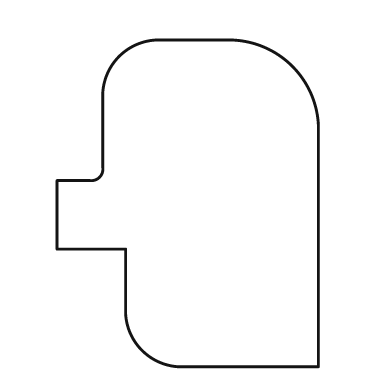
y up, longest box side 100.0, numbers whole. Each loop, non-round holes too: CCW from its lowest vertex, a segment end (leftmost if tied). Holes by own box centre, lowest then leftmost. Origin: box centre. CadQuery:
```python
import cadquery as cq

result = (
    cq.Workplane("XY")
    .moveTo(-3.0, -50.0)
    .lineTo(40.0, -50.0)
    .lineTo(40.0, 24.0)
    .threePointArc((32.0, 42.0), (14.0, 50.0))
    .lineTo(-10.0, 50.0)
    .threePointArc((-21.0, 45.0), (-26.0, 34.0))
    .lineTo(-26.0, 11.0)
    .threePointArc((-27.0, 8.0), (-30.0, 7.0))
    .lineTo(-40.0, 7.0)
    .lineTo(-40.0, -14.0)
    .lineTo(-19.0, -14.0)
    .lineTo(-19.0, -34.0)
    .threePointArc((-14.0, -45.0), (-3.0, -50.0))
    .close()
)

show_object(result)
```